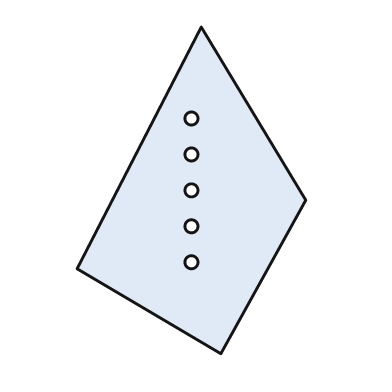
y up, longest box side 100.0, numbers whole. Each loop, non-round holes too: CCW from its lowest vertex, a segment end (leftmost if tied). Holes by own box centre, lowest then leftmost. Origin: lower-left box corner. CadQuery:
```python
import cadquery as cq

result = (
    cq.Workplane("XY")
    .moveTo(44.0, 0.0)
    .lineTo(70.0, 47.0)
    .lineTo(38.0, 100.0)
    .lineTo(0.0, 26.0)
    .close()
    .moveTo(35.0, 28.0)
    .circle(2.0)
    .moveTo(35.0, 39.0)
    .circle(2.0)
    .moveTo(35.0, 50.0)
    .circle(2.0)
    .moveTo(35.0, 61.0)
    .circle(2.0)
    .moveTo(35.0, 72.0)
    .circle(2.0)
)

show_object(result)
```